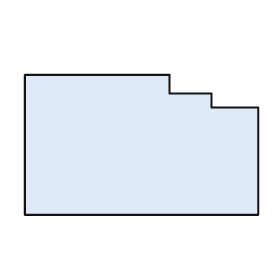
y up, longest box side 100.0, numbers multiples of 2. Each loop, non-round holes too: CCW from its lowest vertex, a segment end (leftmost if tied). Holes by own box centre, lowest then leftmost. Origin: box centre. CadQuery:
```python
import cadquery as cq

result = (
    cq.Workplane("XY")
    .moveTo(-50.0, -30.0)
    .lineTo(50.0, -30.0)
    .lineTo(50.0, 16.0)
    .lineTo(30.0, 16.0)
    .lineTo(30.0, 22.0)
    .lineTo(12.0, 22.0)
    .lineTo(12.0, 30.0)
    .lineTo(-50.0, 30.0)
    .close()
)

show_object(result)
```